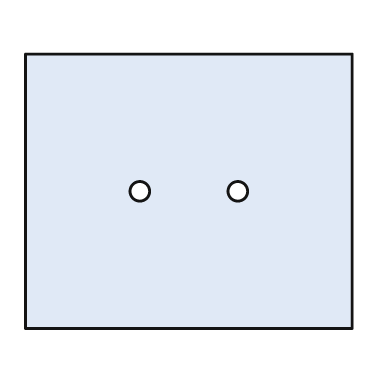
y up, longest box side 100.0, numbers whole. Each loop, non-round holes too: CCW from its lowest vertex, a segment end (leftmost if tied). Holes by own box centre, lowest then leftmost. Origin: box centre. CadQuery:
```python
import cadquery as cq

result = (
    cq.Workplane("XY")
    .moveTo(-50.0, -42.0)
    .lineTo(50.0, -42.0)
    .lineTo(50.0, 42.0)
    .lineTo(-50.0, 42.0)
    .close()
    .moveTo(-15.0, 0.0)
    .circle(3.0)
    .moveTo(15.0, 0.0)
    .circle(3.0)
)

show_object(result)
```